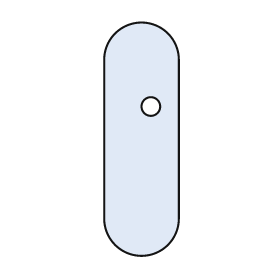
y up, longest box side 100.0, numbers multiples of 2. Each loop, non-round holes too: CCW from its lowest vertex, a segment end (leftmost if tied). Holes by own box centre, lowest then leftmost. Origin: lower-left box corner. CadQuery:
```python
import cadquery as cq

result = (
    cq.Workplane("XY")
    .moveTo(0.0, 16.0)
    .threePointArc((16.0, 0.0), (32.0, 16.0))
    .lineTo(32.0, 84.0)
    .threePointArc((16.0, 100.0), (0.0, 84.0))
    .close()
    .moveTo(20.0, 64.0)
    .circle(4.0)
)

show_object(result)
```